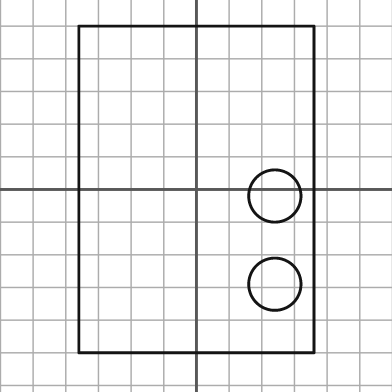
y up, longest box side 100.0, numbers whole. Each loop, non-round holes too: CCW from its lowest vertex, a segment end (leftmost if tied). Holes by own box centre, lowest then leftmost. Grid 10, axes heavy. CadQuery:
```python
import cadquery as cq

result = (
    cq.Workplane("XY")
    .moveTo(-36.0, -50.0)
    .lineTo(36.0, -50.0)
    .lineTo(36.0, 50.0)
    .lineTo(-36.0, 50.0)
    .close()
    .moveTo(24.0, -29.0)
    .circle(8.0)
    .moveTo(24.0, -2.0)
    .circle(8.0)
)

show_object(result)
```